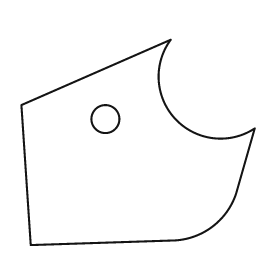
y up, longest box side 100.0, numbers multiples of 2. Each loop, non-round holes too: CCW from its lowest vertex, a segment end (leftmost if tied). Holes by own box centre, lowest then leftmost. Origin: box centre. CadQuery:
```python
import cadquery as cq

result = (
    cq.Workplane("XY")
    .moveTo(-46.0, -44.0)
    .lineTo(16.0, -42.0)
    .threePointArc((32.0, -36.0), (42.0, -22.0))
    .lineTo(50.0, 6.0)
    .threePointArc((16.0, 10.0), (14.0, 44.0))
    .lineTo(-50.0, 16.0)
    .close()
    .moveTo(-14.0, 10.0)
    .circle(6.0)
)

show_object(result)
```